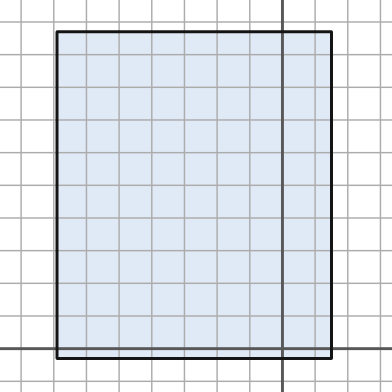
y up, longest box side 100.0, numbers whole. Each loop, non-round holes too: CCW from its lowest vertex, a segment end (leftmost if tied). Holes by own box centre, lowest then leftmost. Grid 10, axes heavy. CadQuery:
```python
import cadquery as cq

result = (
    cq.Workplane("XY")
    .moveTo(-69.0, -3.0)
    .lineTo(15.0, -3.0)
    .lineTo(15.0, 97.0)
    .lineTo(-69.0, 97.0)
    .close()
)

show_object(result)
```